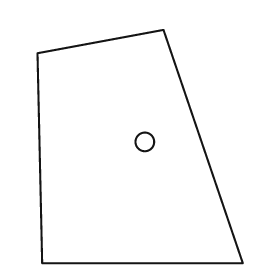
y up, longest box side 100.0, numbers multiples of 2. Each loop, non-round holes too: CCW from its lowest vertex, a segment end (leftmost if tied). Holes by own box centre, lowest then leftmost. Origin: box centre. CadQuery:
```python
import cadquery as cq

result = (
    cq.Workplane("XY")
    .moveTo(-42.0, -50.0)
    .lineTo(44.0, -50.0)
    .lineTo(10.0, 50.0)
    .lineTo(-44.0, 40.0)
    .close()
    .moveTo(2.0, 2.0)
    .circle(4.0)
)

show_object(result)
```